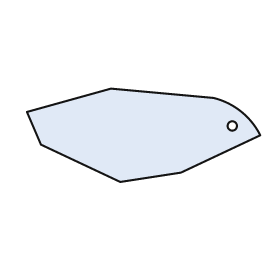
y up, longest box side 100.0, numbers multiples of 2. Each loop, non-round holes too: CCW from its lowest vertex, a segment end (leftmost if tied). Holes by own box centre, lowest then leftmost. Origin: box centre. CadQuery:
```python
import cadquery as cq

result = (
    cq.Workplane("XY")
    .moveTo(-10.0, -20.0)
    .lineTo(16.0, -16.0)
    .lineTo(50.0, 0.0)
    .threePointArc((42.0, 10.0), (30.0, 16.0))
    .lineTo(-14.0, 20.0)
    .lineTo(-50.0, 10.0)
    .lineTo(-44.0, -4.0)
    .close()
    .moveTo(38.0, 4.0)
    .circle(2.0)
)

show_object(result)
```